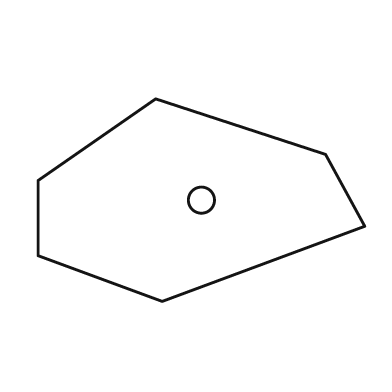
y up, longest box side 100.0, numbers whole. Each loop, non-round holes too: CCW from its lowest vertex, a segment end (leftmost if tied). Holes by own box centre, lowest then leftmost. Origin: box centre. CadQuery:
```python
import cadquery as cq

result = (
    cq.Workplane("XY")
    .moveTo(-12.0, -31.0)
    .lineTo(50.0, -8.0)
    .lineTo(38.0, 14.0)
    .lineTo(-14.0, 31.0)
    .lineTo(-50.0, 6.0)
    .lineTo(-50.0, -17.0)
    .close()
    .moveTo(0.0, 0.0)
    .circle(4.0)
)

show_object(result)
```